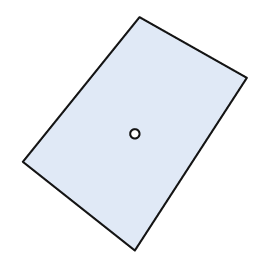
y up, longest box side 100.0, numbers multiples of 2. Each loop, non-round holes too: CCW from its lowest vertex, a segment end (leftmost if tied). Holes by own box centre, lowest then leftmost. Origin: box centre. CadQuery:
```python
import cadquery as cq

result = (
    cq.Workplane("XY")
    .moveTo(0.0, -50.0)
    .lineTo(48.0, 24.0)
    .lineTo(2.0, 50.0)
    .lineTo(-48.0, -12.0)
    .close()
    .moveTo(0.0, 0.0)
    .circle(2.0)
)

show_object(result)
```